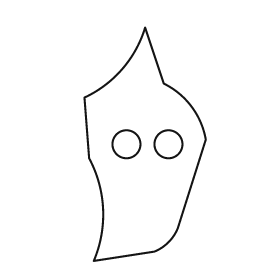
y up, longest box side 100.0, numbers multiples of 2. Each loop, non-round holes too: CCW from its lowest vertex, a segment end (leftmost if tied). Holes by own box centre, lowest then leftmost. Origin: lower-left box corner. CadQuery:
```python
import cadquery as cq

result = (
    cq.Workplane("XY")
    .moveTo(4.0, 0.0)
    .lineTo(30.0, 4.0)
    .threePointArc((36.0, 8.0), (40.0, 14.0))
    .lineTo(52.0, 52.0)
    .threePointArc((46.0, 66.0), (34.0, 76.0))
    .lineTo(26.0, 100.0)
    .threePointArc((16.0, 82.0), (0.0, 70.0))
    .lineTo(2.0, 44.0)
    .threePointArc((8.0, 22.0), (4.0, 0.0))
    .close()
    .moveTo(18.0, 50.0)
    .circle(6.0)
    .moveTo(36.0, 50.0)
    .circle(6.0)
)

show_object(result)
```